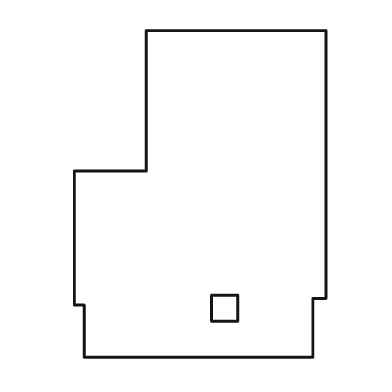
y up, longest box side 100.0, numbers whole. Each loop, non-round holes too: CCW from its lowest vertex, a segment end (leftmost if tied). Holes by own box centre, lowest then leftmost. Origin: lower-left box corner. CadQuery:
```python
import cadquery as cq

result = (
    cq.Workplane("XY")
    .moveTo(3.0, 0.0)
    .lineTo(73.0, 0.0)
    .lineTo(73.0, 18.0)
    .lineTo(77.0, 18.0)
    .lineTo(77.0, 100.0)
    .lineTo(22.0, 100.0)
    .lineTo(22.0, 57.0)
    .lineTo(0.0, 57.0)
    .lineTo(0.0, 16.0)
    .lineTo(3.0, 16.0)
    .close()
    .moveTo(42.0, 11.0)
    .lineTo(50.0, 11.0)
    .lineTo(50.0, 19.0)
    .lineTo(42.0, 19.0)
    .close()
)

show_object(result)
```